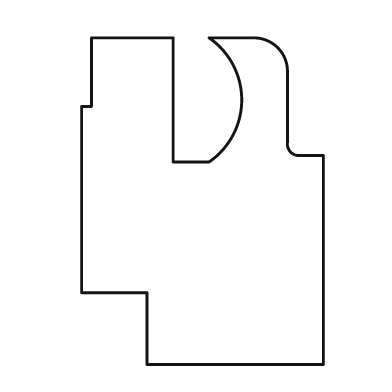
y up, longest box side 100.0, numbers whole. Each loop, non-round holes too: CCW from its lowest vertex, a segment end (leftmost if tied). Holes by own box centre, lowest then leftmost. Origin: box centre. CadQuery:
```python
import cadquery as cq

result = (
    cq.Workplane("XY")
    .moveTo(-17.0, -50.0)
    .lineTo(37.0, -50.0)
    .lineTo(37.0, 14.0)
    .lineTo(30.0, 14.0)
    .threePointArc((27.0, 15.0), (26.0, 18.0))
    .lineTo(26.0, 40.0)
    .threePointArc((23.0, 47.0), (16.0, 50.0))
    .lineTo(2.0, 50.0)
    .threePointArc((12.0, 31.0), (2.0, 12.0))
    .lineTo(-9.0, 12.0)
    .lineTo(-9.0, 50.0)
    .lineTo(-34.0, 50.0)
    .lineTo(-34.0, 29.0)
    .lineTo(-37.0, 29.0)
    .lineTo(-37.0, -28.0)
    .lineTo(-17.0, -28.0)
    .close()
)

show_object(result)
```